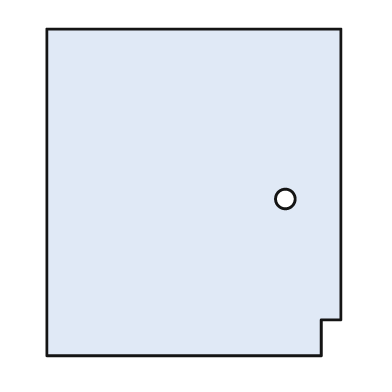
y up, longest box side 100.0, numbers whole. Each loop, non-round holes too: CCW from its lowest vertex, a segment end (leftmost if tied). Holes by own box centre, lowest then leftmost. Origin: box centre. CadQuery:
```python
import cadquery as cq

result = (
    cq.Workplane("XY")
    .moveTo(-45.0, -50.0)
    .lineTo(39.0, -50.0)
    .lineTo(39.0, -39.0)
    .lineTo(45.0, -39.0)
    .lineTo(45.0, 50.0)
    .lineTo(-45.0, 50.0)
    .close()
    .moveTo(28.0, -2.0)
    .circle(3.0)
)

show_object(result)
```